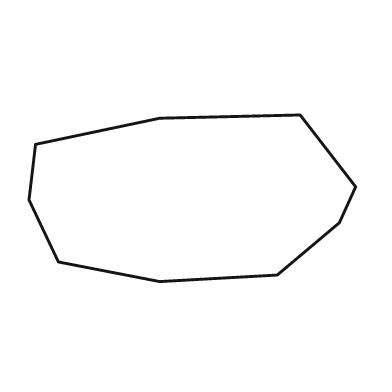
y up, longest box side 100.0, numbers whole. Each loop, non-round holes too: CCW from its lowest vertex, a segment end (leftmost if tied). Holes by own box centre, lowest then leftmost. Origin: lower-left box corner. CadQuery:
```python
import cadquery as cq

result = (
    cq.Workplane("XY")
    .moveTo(40.0, 0.0)
    .lineTo(76.0, 2.0)
    .lineTo(95.0, 18.0)
    .lineTo(100.0, 29.0)
    .lineTo(83.0, 51.0)
    .lineTo(40.0, 50.0)
    .lineTo(2.0, 42.0)
    .lineTo(0.0, 25.0)
    .lineTo(9.0, 6.0)
    .close()
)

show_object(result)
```